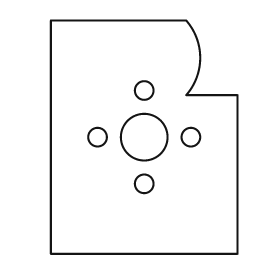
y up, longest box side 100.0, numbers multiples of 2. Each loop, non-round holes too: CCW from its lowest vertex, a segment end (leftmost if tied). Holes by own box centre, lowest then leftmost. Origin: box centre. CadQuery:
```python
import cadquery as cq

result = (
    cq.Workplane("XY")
    .moveTo(-40.0, -50.0)
    .lineTo(40.0, -50.0)
    .lineTo(40.0, 18.0)
    .lineTo(18.0, 18.0)
    .threePointArc((24.0, 34.0), (18.0, 50.0))
    .lineTo(-40.0, 50.0)
    .close()
    .moveTo(0.0, -20.0)
    .circle(4.0)
    .moveTo(-20.0, 0.0)
    .circle(4.0)
    .moveTo(0.0, 0.0)
    .circle(10.0)
    .moveTo(20.0, 0.0)
    .circle(4.0)
    .moveTo(0.0, 20.0)
    .circle(4.0)
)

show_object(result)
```